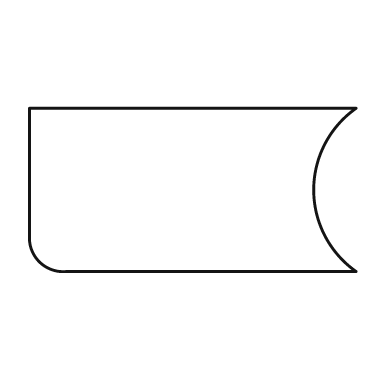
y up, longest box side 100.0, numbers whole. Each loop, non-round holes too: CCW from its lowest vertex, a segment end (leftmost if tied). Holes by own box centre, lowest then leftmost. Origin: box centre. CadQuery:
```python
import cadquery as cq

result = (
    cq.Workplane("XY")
    .moveTo(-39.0, -25.0)
    .lineTo(50.0, -25.0)
    .threePointArc((37.0, 0.0), (50.0, 25.0))
    .lineTo(-50.0, 25.0)
    .lineTo(-50.0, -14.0)
    .threePointArc((-47.0, -22.0), (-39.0, -25.0))
    .close()
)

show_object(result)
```